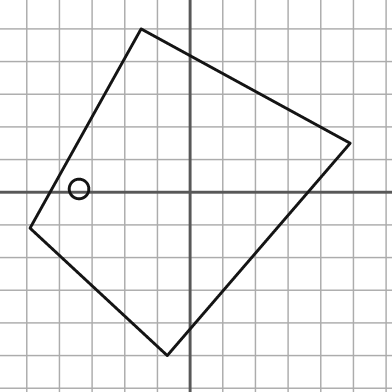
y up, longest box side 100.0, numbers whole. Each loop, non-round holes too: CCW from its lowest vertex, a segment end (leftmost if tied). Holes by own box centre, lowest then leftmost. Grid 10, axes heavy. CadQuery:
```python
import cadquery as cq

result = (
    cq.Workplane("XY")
    .moveTo(-7.0, -50.0)
    .lineTo(49.0, 15.0)
    .lineTo(-15.0, 50.0)
    .lineTo(-49.0, -11.0)
    .close()
    .moveTo(-34.0, 1.0)
    .circle(3.0)
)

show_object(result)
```